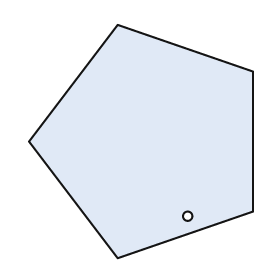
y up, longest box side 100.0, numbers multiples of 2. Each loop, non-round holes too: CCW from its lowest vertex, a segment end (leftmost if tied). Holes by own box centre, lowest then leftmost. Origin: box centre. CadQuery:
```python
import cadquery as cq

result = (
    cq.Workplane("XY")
    .moveTo(-10.0, -50.0)
    .lineTo(48.0, -30.0)
    .lineTo(48.0, 30.0)
    .lineTo(-10.0, 50.0)
    .lineTo(-48.0, 0.0)
    .close()
    .moveTo(20.0, -32.0)
    .circle(2.0)
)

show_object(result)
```